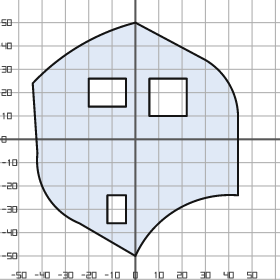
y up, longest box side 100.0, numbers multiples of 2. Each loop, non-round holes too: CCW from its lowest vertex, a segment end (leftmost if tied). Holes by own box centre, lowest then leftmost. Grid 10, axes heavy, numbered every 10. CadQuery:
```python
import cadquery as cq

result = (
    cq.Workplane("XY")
    .moveTo(0.0, -50.0)
    .threePointArc((18.0, -30.0), (44.0, -24.0))
    .lineTo(44.0, 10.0)
    .threePointArc((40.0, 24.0), (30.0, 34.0))
    .lineTo(0.0, 50.0)
    .threePointArc((-24.0, 40.0), (-44.0, 24.0))
    .lineTo(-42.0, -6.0)
    .threePointArc((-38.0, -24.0), (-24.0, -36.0))
    .close()
    .moveTo(-12.0, -36.0)
    .lineTo(-4.0, -36.0)
    .lineTo(-4.0, -24.0)
    .lineTo(-12.0, -24.0)
    .close()
    .moveTo(6.0, 10.0)
    .lineTo(22.0, 10.0)
    .lineTo(22.0, 26.0)
    .lineTo(6.0, 26.0)
    .close()
    .moveTo(-20.0, 14.0)
    .lineTo(-4.0, 14.0)
    .lineTo(-4.0, 26.0)
    .lineTo(-20.0, 26.0)
    .close()
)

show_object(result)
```